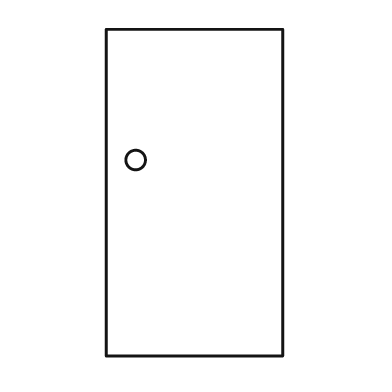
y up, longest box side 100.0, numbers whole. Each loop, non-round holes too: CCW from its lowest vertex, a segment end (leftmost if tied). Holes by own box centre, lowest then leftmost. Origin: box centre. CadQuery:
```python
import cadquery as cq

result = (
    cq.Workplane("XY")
    .moveTo(-27.0, -50.0)
    .lineTo(27.0, -50.0)
    .lineTo(27.0, 50.0)
    .lineTo(-27.0, 50.0)
    .close()
    .moveTo(-18.0, 10.0)
    .circle(3.0)
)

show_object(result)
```